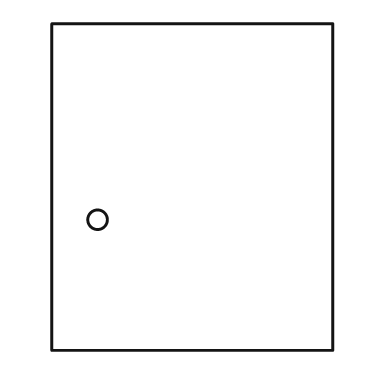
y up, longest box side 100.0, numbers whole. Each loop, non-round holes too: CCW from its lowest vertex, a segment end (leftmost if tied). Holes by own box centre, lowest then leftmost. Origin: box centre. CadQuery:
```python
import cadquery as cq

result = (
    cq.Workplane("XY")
    .moveTo(-43.0, -50.0)
    .lineTo(43.0, -50.0)
    .lineTo(43.0, 50.0)
    .lineTo(-43.0, 50.0)
    .close()
    .moveTo(-29.0, -10.0)
    .circle(3.0)
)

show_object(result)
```